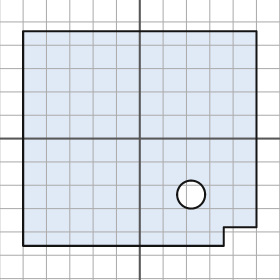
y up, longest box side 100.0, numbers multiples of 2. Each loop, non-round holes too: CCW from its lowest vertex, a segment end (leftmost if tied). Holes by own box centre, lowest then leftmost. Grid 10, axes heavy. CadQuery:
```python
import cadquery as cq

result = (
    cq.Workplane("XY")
    .moveTo(-50.0, -46.0)
    .lineTo(36.0, -46.0)
    .lineTo(36.0, -38.0)
    .lineTo(50.0, -38.0)
    .lineTo(50.0, 46.0)
    .lineTo(-50.0, 46.0)
    .close()
    .moveTo(22.0, -24.0)
    .circle(6.0)
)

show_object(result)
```